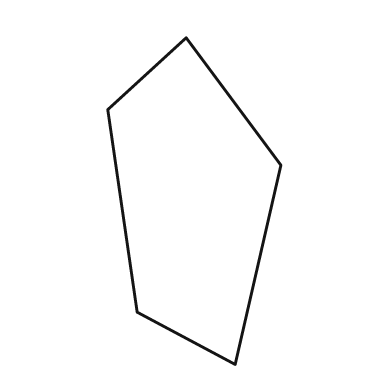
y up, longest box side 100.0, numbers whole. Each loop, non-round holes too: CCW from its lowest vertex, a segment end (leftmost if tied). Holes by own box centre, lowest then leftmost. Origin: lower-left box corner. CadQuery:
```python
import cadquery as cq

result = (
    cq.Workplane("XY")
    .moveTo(39.0, 0.0)
    .lineTo(53.0, 61.0)
    .lineTo(24.0, 100.0)
    .lineTo(0.0, 78.0)
    .lineTo(9.0, 16.0)
    .close()
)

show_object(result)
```